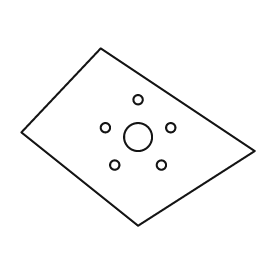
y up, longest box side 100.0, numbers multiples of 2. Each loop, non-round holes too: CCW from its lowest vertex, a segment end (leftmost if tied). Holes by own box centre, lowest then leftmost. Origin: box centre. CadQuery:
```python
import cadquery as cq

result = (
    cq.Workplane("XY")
    .moveTo(0.0, -38.0)
    .lineTo(50.0, -6.0)
    .lineTo(-16.0, 38.0)
    .lineTo(-50.0, 2.0)
    .close()
    .moveTo(-10.0, -12.0)
    .circle(2.0)
    .moveTo(10.0, -12.0)
    .circle(2.0)
    .moveTo(0.0, 0.0)
    .circle(6.0)
    .moveTo(-14.0, 4.0)
    .circle(2.0)
    .moveTo(14.0, 4.0)
    .circle(2.0)
    .moveTo(0.0, 16.0)
    .circle(2.0)
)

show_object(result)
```